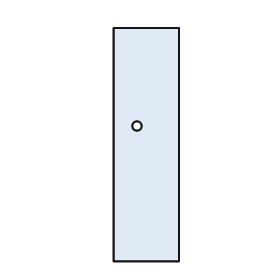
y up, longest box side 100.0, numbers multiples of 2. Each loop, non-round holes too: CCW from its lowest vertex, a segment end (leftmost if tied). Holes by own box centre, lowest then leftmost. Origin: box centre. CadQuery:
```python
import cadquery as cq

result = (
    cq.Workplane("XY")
    .moveTo(-14.0, -50.0)
    .lineTo(14.0, -50.0)
    .lineTo(14.0, 50.0)
    .lineTo(-14.0, 50.0)
    .close()
    .moveTo(-4.0, 8.0)
    .circle(2.0)
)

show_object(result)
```